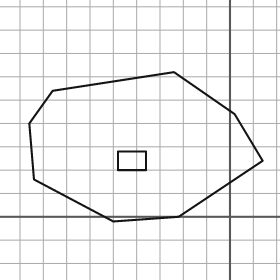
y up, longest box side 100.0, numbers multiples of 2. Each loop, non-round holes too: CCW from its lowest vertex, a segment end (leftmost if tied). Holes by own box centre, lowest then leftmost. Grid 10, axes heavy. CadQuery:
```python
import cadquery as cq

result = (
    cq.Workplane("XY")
    .moveTo(-50.0, -2.0)
    .lineTo(-22.0, 0.0)
    .lineTo(14.0, 24.0)
    .lineTo(2.0, 44.0)
    .lineTo(-24.0, 62.0)
    .lineTo(-76.0, 54.0)
    .lineTo(-86.0, 40.0)
    .lineTo(-84.0, 16.0)
    .close()
    .moveTo(-48.0, 20.0)
    .lineTo(-36.0, 20.0)
    .lineTo(-36.0, 28.0)
    .lineTo(-48.0, 28.0)
    .close()
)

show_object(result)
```